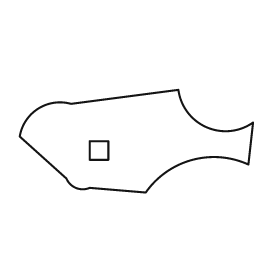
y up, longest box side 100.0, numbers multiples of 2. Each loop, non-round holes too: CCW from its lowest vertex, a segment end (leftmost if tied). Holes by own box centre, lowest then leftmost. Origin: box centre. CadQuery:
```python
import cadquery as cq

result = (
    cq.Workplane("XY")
    .moveTo(4.0, -22.0)
    .threePointArc((24.0, -8.0), (48.0, -10.0))
    .lineTo(50.0, 8.0)
    .threePointArc((30.0, 6.0), (18.0, 22.0))
    .lineTo(-28.0, 16.0)
    .threePointArc((-42.0, 14.0), (-50.0, 2.0))
    .lineTo(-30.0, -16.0)
    .threePointArc((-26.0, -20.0), (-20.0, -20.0))
    .close()
    .moveTo(-20.0, -8.0)
    .lineTo(-12.0, -8.0)
    .lineTo(-12.0, 0.0)
    .lineTo(-20.0, 0.0)
    .close()
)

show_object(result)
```